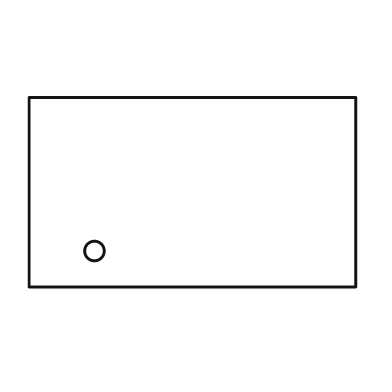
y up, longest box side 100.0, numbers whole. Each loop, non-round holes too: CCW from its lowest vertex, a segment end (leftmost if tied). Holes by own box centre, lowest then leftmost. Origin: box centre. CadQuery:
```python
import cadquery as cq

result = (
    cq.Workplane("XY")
    .moveTo(-50.0, -29.0)
    .lineTo(50.0, -29.0)
    .lineTo(50.0, 29.0)
    .lineTo(-50.0, 29.0)
    .close()
    .moveTo(-30.0, -18.0)
    .circle(3.0)
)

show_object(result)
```